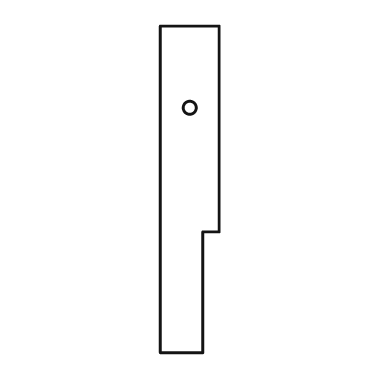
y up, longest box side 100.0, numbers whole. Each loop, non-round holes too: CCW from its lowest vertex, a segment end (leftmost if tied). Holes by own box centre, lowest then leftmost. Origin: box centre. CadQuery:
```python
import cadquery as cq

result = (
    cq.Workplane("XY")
    .moveTo(-9.0, -50.0)
    .lineTo(4.0, -50.0)
    .lineTo(4.0, -13.0)
    .lineTo(9.0, -13.0)
    .lineTo(9.0, 50.0)
    .lineTo(-9.0, 50.0)
    .close()
    .moveTo(0.0, 25.0)
    .circle(2.0)
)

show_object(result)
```